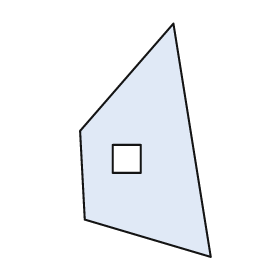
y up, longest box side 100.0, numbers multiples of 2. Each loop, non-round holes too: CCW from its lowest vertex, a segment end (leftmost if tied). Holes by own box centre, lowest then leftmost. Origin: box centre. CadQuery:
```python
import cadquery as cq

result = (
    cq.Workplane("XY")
    .moveTo(28.0, -50.0)
    .lineTo(12.0, 50.0)
    .lineTo(-28.0, 4.0)
    .lineTo(-26.0, -34.0)
    .close()
    .moveTo(-14.0, -14.0)
    .lineTo(-2.0, -14.0)
    .lineTo(-2.0, -2.0)
    .lineTo(-14.0, -2.0)
    .close()
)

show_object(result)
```